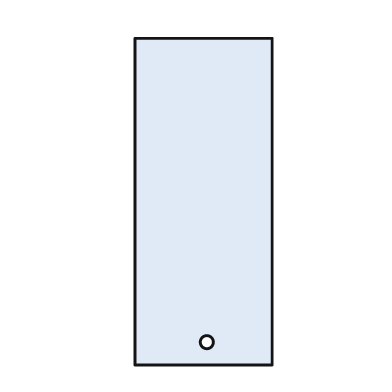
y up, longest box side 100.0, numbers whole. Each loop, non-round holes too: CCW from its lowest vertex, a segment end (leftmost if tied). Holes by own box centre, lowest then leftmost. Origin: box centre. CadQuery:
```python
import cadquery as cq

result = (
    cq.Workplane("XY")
    .moveTo(-21.0, -50.0)
    .lineTo(21.0, -50.0)
    .lineTo(21.0, 50.0)
    .lineTo(-21.0, 50.0)
    .close()
    .moveTo(1.0, -43.0)
    .circle(2.0)
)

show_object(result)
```